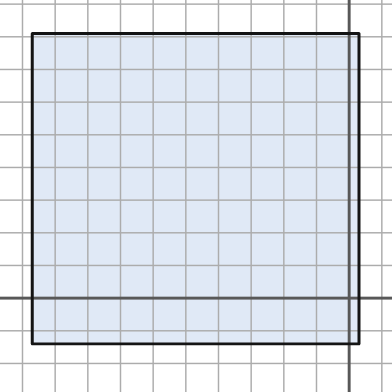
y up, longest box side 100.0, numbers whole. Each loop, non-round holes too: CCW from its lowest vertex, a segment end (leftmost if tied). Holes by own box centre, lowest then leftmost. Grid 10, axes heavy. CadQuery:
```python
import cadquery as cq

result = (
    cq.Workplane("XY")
    .moveTo(-97.0, -14.0)
    .lineTo(3.0, -14.0)
    .lineTo(3.0, 81.0)
    .lineTo(-97.0, 81.0)
    .close()
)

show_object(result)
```